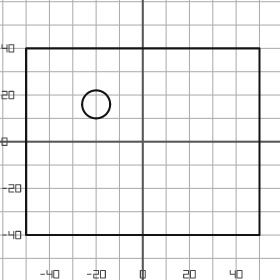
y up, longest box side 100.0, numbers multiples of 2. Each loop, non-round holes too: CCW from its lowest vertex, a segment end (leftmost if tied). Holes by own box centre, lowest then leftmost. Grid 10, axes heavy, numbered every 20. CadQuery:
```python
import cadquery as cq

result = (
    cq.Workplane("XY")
    .moveTo(-50.0, -40.0)
    .lineTo(50.0, -40.0)
    .lineTo(50.0, 40.0)
    .lineTo(-50.0, 40.0)
    .close()
    .moveTo(-20.0, 16.0)
    .circle(6.0)
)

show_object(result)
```